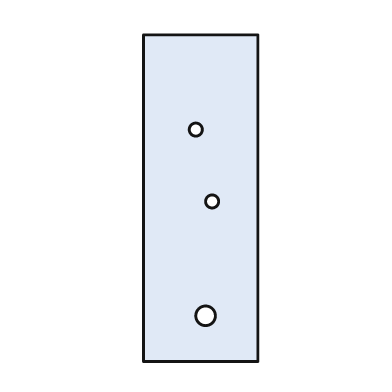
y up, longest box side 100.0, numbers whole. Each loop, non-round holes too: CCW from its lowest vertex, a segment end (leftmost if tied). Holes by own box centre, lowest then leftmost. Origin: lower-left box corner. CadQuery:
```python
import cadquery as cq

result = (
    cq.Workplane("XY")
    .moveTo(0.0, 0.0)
    .lineTo(35.0, 0.0)
    .lineTo(35.0, 100.0)
    .lineTo(0.0, 100.0)
    .close()
    .moveTo(19.0, 14.0)
    .circle(3.0)
    .moveTo(21.0, 49.0)
    .circle(2.0)
    .moveTo(16.0, 71.0)
    .circle(2.0)
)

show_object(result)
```